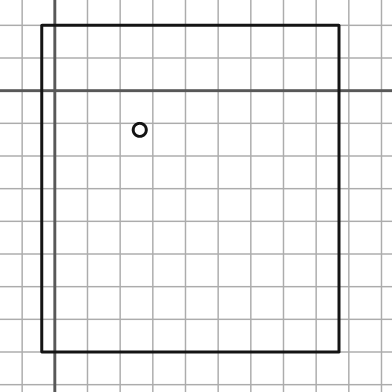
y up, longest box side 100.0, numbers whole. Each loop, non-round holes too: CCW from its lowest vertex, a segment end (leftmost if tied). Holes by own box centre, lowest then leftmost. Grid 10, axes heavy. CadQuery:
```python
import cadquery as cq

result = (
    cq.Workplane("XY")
    .moveTo(-4.0, -80.0)
    .lineTo(87.0, -80.0)
    .lineTo(87.0, 20.0)
    .lineTo(-4.0, 20.0)
    .close()
    .moveTo(26.0, -12.0)
    .circle(2.0)
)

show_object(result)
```